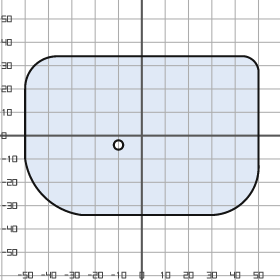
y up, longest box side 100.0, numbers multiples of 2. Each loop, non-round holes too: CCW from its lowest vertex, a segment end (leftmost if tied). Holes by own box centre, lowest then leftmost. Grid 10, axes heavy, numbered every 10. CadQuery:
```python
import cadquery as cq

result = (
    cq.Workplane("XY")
    .moveTo(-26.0, -34.0)
    .lineTo(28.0, -34.0)
    .threePointArc((44.0, -28.0), (50.0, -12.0))
    .lineTo(50.0, 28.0)
    .threePointArc((48.0, 32.0), (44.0, 34.0))
    .lineTo(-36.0, 34.0)
    .threePointArc((-46.0, 30.0), (-50.0, 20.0))
    .lineTo(-50.0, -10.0)
    .threePointArc((-42.0, -26.0), (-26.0, -34.0))
    .close()
    .moveTo(-10.0, -4.0)
    .circle(2.0)
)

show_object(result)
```